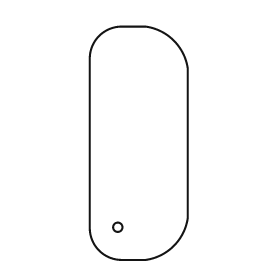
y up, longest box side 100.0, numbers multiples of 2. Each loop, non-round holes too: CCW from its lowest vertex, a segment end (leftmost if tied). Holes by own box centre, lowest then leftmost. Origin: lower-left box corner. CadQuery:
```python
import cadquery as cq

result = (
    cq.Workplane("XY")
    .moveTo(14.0, 0.0)
    .lineTo(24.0, 0.0)
    .threePointArc((36.0, 6.0), (42.0, 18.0))
    .lineTo(42.0, 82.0)
    .threePointArc((36.0, 94.0), (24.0, 100.0))
    .lineTo(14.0, 100.0)
    .threePointArc((4.0, 96.0), (0.0, 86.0))
    .lineTo(0.0, 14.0)
    .threePointArc((4.0, 4.0), (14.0, 0.0))
    .close()
    .moveTo(12.0, 14.0)
    .circle(2.0)
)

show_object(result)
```